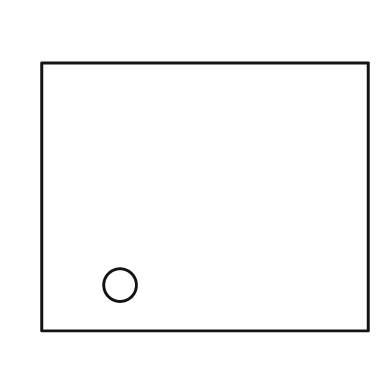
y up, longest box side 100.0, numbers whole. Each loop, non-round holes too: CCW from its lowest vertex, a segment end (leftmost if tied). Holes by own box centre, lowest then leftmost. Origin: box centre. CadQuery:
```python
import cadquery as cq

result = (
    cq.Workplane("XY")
    .moveTo(-50.0, -41.0)
    .lineTo(50.0, -41.0)
    .lineTo(50.0, 41.0)
    .lineTo(-50.0, 41.0)
    .close()
    .moveTo(-26.0, -27.0)
    .circle(5.0)
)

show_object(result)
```